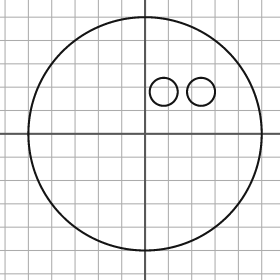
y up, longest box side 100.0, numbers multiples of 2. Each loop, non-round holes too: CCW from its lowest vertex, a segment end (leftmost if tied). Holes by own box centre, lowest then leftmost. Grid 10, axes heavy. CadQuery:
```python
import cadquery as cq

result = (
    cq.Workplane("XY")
    .moveTo(0.0, 0.0)
    .circle(50.0)
    .moveTo(8.0, 18.0)
    .circle(6.0)
    .moveTo(24.0, 18.0)
    .circle(6.0)
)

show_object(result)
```